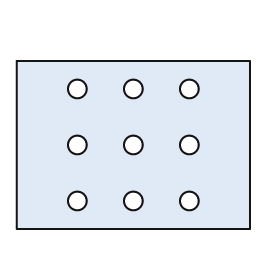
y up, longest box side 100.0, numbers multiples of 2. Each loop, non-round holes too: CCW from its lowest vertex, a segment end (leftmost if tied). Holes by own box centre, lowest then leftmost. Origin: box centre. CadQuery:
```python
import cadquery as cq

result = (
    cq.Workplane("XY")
    .moveTo(-50.0, -36.0)
    .lineTo(50.0, -36.0)
    .lineTo(50.0, 36.0)
    .lineTo(-50.0, 36.0)
    .close()
    .moveTo(-24.0, -24.0)
    .circle(4.0)
    .moveTo(0.0, -24.0)
    .circle(4.0)
    .moveTo(24.0, -24.0)
    .circle(4.0)
    .moveTo(-24.0, 0.0)
    .circle(4.0)
    .moveTo(0.0, 0.0)
    .circle(4.0)
    .moveTo(24.0, 0.0)
    .circle(4.0)
    .moveTo(-24.0, 24.0)
    .circle(4.0)
    .moveTo(0.0, 24.0)
    .circle(4.0)
    .moveTo(24.0, 24.0)
    .circle(4.0)
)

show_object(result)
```